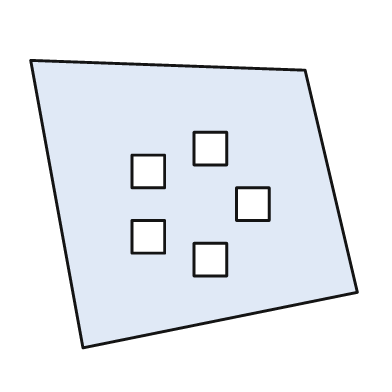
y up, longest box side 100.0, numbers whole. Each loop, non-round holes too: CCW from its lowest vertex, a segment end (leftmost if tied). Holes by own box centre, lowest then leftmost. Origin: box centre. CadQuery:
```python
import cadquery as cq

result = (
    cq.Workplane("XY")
    .moveTo(-34.0, -44.0)
    .lineTo(50.0, -27.0)
    .lineTo(34.0, 41.0)
    .lineTo(-50.0, 44.0)
    .close()
    .moveTo(0.0, -22.0)
    .lineTo(10.0, -22.0)
    .lineTo(10.0, -12.0)
    .lineTo(0.0, -12.0)
    .close()
    .moveTo(-19.0, -15.0)
    .lineTo(-9.0, -15.0)
    .lineTo(-9.0, -5.0)
    .lineTo(-19.0, -5.0)
    .close()
    .moveTo(13.0, -5.0)
    .lineTo(23.0, -5.0)
    .lineTo(23.0, 5.0)
    .lineTo(13.0, 5.0)
    .close()
    .moveTo(-19.0, 5.0)
    .lineTo(-9.0, 5.0)
    .lineTo(-9.0, 15.0)
    .lineTo(-19.0, 15.0)
    .close()
    .moveTo(0.0, 12.0)
    .lineTo(10.0, 12.0)
    .lineTo(10.0, 22.0)
    .lineTo(0.0, 22.0)
    .close()
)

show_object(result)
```